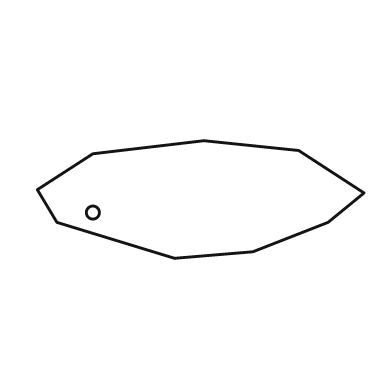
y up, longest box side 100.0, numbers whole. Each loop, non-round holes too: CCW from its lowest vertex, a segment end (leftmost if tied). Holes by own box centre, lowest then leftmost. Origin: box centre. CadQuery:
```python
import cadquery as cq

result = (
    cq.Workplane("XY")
    .moveTo(-8.0, -18.0)
    .lineTo(16.0, -16.0)
    .lineTo(39.0, -7.0)
    .lineTo(50.0, 2.0)
    .lineTo(30.0, 15.0)
    .lineTo(1.0, 18.0)
    .lineTo(-33.0, 14.0)
    .lineTo(-50.0, 3.0)
    .lineTo(-44.0, -7.0)
    .close()
    .moveTo(-33.0, -4.0)
    .circle(2.0)
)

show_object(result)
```